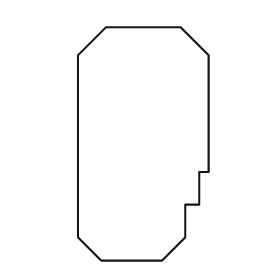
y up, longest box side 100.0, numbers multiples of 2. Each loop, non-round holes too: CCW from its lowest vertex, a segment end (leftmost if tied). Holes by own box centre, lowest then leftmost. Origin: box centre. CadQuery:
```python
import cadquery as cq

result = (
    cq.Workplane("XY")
    .moveTo(-18.0, -50.0)
    .lineTo(8.0, -50.0)
    .lineTo(18.0, -40.0)
    .lineTo(18.0, -26.0)
    .lineTo(24.0, -26.0)
    .lineTo(24.0, -12.0)
    .lineTo(28.0, -12.0)
    .lineTo(28.0, 38.0)
    .lineTo(16.0, 50.0)
    .lineTo(-16.0, 50.0)
    .lineTo(-28.0, 38.0)
    .lineTo(-28.0, -40.0)
    .close()
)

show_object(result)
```